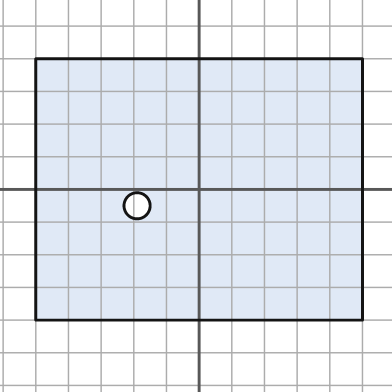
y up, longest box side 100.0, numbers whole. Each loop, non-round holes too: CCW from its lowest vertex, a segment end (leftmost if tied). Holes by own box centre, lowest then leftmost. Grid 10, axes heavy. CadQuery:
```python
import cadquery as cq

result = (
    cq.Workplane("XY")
    .moveTo(-50.0, -40.0)
    .lineTo(50.0, -40.0)
    .lineTo(50.0, 40.0)
    .lineTo(-50.0, 40.0)
    .close()
    .moveTo(-19.0, -5.0)
    .circle(4.0)
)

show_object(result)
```